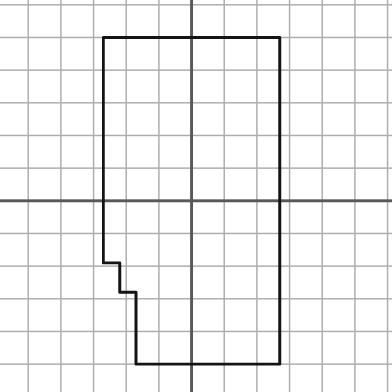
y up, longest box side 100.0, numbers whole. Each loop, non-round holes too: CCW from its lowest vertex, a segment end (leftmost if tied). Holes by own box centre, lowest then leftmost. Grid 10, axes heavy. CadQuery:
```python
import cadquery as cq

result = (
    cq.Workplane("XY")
    .moveTo(-17.0, -50.0)
    .lineTo(27.0, -50.0)
    .lineTo(27.0, 50.0)
    .lineTo(-27.0, 50.0)
    .lineTo(-27.0, -19.0)
    .lineTo(-22.0, -19.0)
    .lineTo(-22.0, -28.0)
    .lineTo(-17.0, -28.0)
    .close()
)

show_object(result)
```